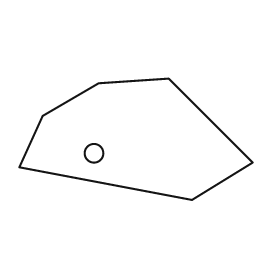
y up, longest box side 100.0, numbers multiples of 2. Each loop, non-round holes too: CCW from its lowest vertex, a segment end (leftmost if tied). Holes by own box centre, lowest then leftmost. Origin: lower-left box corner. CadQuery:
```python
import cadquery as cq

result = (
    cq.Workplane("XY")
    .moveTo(74.0, 0.0)
    .lineTo(100.0, 16.0)
    .lineTo(64.0, 52.0)
    .lineTo(34.0, 50.0)
    .lineTo(10.0, 36.0)
    .lineTo(0.0, 14.0)
    .close()
    .moveTo(32.0, 20.0)
    .circle(4.0)
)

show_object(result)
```